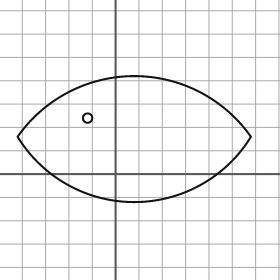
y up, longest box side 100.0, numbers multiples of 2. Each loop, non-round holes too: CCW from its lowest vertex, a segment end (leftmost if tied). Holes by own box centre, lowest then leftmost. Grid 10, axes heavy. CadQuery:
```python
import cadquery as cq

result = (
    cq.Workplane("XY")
    .moveTo(-42.0, 16.0)
    .threePointArc((8.0, -12.0), (58.0, 16.0))
    .threePointArc((8.0, 42.0), (-42.0, 16.0))
    .close()
    .moveTo(-12.0, 24.0)
    .circle(2.0)
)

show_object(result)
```